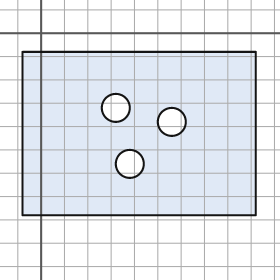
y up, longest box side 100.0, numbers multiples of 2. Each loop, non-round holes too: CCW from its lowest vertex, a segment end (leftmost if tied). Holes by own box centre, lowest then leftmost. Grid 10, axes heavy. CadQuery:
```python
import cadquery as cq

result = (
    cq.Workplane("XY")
    .moveTo(-8.0, -78.0)
    .lineTo(92.0, -78.0)
    .lineTo(92.0, -8.0)
    .lineTo(-8.0, -8.0)
    .close()
    .moveTo(38.0, -56.0)
    .circle(6.0)
    .moveTo(56.0, -38.0)
    .circle(6.0)
    .moveTo(32.0, -32.0)
    .circle(6.0)
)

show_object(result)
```